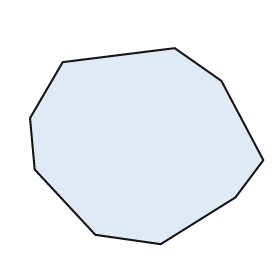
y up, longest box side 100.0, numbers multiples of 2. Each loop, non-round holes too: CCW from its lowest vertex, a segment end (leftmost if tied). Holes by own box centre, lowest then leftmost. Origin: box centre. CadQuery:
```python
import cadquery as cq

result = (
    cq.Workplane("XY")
    .moveTo(6.0, -42.0)
    .lineTo(38.0, -22.0)
    .lineTo(50.0, -6.0)
    .lineTo(32.0, 28.0)
    .lineTo(12.0, 42.0)
    .lineTo(-36.0, 36.0)
    .lineTo(-50.0, 12.0)
    .lineTo(-48.0, -10.0)
    .lineTo(-22.0, -38.0)
    .close()
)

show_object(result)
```